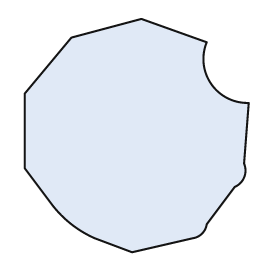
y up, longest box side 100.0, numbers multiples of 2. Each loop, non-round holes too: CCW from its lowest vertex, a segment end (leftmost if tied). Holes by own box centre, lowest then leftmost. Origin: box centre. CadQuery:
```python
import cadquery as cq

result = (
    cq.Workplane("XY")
    .moveTo(-2.0, -50.0)
    .lineTo(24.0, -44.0)
    .threePointArc((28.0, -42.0), (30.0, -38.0))
    .lineTo(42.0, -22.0)
    .threePointArc((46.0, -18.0), (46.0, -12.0))
    .lineTo(48.0, 14.0)
    .threePointArc((32.0, 22.0), (30.0, 40.0))
    .lineTo(2.0, 50.0)
    .lineTo(-28.0, 42.0)
    .lineTo(-48.0, 18.0)
    .lineTo(-48.0, -14.0)
    .lineTo(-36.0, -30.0)
    .threePointArc((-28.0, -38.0), (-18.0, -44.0))
    .close()
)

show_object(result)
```